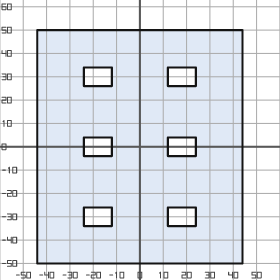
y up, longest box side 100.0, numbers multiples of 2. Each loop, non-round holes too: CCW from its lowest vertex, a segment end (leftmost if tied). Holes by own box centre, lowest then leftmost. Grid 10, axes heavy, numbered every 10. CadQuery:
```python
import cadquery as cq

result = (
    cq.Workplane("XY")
    .moveTo(-44.0, -50.0)
    .lineTo(44.0, -50.0)
    .lineTo(44.0, 50.0)
    .lineTo(-44.0, 50.0)
    .close()
    .moveTo(-24.0, -34.0)
    .lineTo(-12.0, -34.0)
    .lineTo(-12.0, -26.0)
    .lineTo(-24.0, -26.0)
    .close()
    .moveTo(12.0, -34.0)
    .lineTo(24.0, -34.0)
    .lineTo(24.0, -26.0)
    .lineTo(12.0, -26.0)
    .close()
    .moveTo(-24.0, -4.0)
    .lineTo(-12.0, -4.0)
    .lineTo(-12.0, 4.0)
    .lineTo(-24.0, 4.0)
    .close()
    .moveTo(12.0, -4.0)
    .lineTo(24.0, -4.0)
    .lineTo(24.0, 4.0)
    .lineTo(12.0, 4.0)
    .close()
    .moveTo(-24.0, 26.0)
    .lineTo(-12.0, 26.0)
    .lineTo(-12.0, 34.0)
    .lineTo(-24.0, 34.0)
    .close()
    .moveTo(12.0, 26.0)
    .lineTo(24.0, 26.0)
    .lineTo(24.0, 34.0)
    .lineTo(12.0, 34.0)
    .close()
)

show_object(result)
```